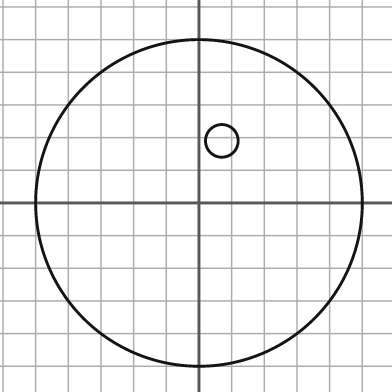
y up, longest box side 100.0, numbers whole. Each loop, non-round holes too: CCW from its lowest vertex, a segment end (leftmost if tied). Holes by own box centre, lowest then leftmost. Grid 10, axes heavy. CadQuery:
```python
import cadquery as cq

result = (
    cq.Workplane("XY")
    .moveTo(0.0, 0.0)
    .circle(50.0)
    .moveTo(7.0, 19.0)
    .circle(5.0)
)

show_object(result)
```